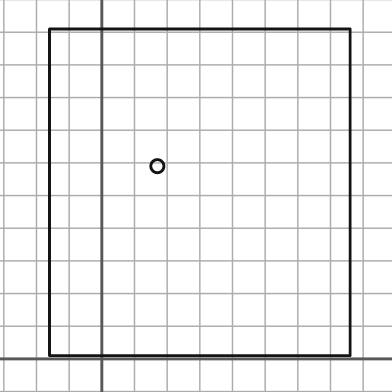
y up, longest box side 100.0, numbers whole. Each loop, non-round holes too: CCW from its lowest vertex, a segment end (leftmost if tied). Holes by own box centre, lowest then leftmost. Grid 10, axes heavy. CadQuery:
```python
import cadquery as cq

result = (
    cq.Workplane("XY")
    .moveTo(-16.0, 1.0)
    .lineTo(76.0, 1.0)
    .lineTo(76.0, 101.0)
    .lineTo(-16.0, 101.0)
    .close()
    .moveTo(17.0, 59.0)
    .circle(2.0)
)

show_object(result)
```